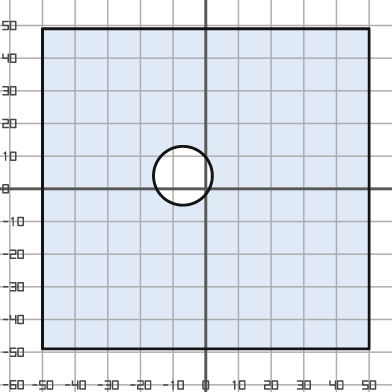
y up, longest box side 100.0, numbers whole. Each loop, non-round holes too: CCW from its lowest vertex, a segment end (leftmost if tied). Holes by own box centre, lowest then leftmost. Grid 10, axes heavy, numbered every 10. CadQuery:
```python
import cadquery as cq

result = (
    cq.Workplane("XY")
    .moveTo(-50.0, -49.0)
    .lineTo(50.0, -49.0)
    .lineTo(50.0, 49.0)
    .lineTo(-50.0, 49.0)
    .close()
    .moveTo(-7.0, 4.0)
    .circle(9.0)
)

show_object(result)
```